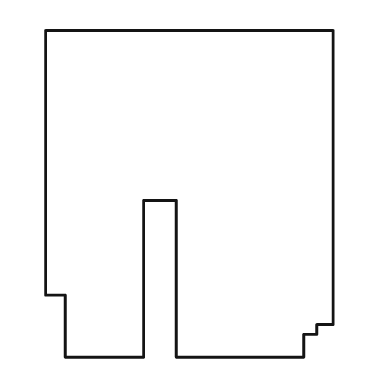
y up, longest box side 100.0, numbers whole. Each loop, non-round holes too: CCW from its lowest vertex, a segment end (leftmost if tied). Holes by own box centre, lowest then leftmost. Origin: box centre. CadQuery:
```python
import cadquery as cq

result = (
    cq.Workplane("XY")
    .moveTo(-38.0, -50.0)
    .lineTo(-14.0, -50.0)
    .lineTo(-14.0, -2.0)
    .lineTo(-4.0, -2.0)
    .lineTo(-4.0, -50.0)
    .lineTo(35.0, -50.0)
    .lineTo(35.0, -43.0)
    .lineTo(39.0, -43.0)
    .lineTo(39.0, -40.0)
    .lineTo(44.0, -40.0)
    .lineTo(44.0, 50.0)
    .lineTo(-44.0, 50.0)
    .lineTo(-44.0, -31.0)
    .lineTo(-38.0, -31.0)
    .close()
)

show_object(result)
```